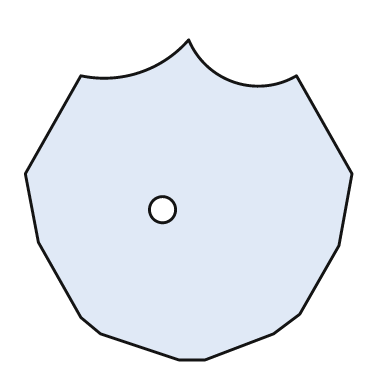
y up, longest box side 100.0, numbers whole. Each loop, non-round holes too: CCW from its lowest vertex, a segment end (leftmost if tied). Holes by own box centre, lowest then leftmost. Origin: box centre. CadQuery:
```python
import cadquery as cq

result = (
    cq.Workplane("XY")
    .moveTo(-3.0, -49.0)
    .lineTo(5.0, -49.0)
    .lineTo(26.0, -41.0)
    .lineTo(34.0, -35.0)
    .lineTo(46.0, -14.0)
    .lineTo(50.0, 8.0)
    .lineTo(33.0, 38.0)
    .threePointArc((14.0, 36.0), (0.0, 49.0))
    .threePointArc((-15.0, 39.0), (-33.0, 38.0))
    .lineTo(-50.0, 8.0)
    .lineTo(-46.0, -13.0)
    .lineTo(-33.0, -36.0)
    .lineTo(-27.0, -41.0)
    .close()
    .moveTo(-8.0, -3.0)
    .circle(4.0)
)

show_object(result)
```